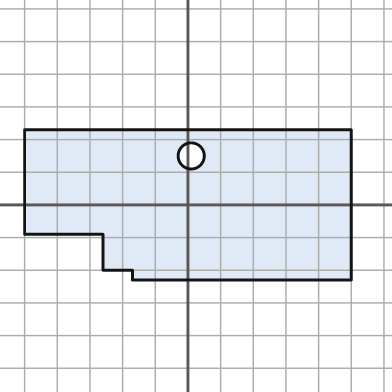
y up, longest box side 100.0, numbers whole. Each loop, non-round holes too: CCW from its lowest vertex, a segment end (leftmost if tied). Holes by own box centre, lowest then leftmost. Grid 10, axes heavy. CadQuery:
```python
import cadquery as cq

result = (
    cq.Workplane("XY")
    .moveTo(-17.0, -23.0)
    .lineTo(50.0, -23.0)
    .lineTo(50.0, 23.0)
    .lineTo(-50.0, 23.0)
    .lineTo(-50.0, -9.0)
    .lineTo(-26.0, -9.0)
    .lineTo(-26.0, -20.0)
    .lineTo(-17.0, -20.0)
    .close()
    .moveTo(1.0, 15.0)
    .circle(4.0)
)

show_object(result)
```